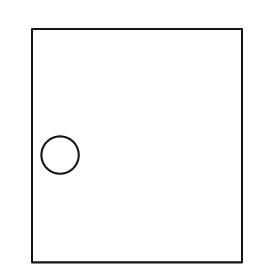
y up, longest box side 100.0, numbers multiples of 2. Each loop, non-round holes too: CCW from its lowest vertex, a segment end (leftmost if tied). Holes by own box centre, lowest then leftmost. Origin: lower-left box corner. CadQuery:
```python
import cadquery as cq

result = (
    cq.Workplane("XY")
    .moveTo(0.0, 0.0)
    .lineTo(90.0, 0.0)
    .lineTo(90.0, 100.0)
    .lineTo(0.0, 100.0)
    .close()
    .moveTo(12.0, 46.0)
    .circle(8.0)
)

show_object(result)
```